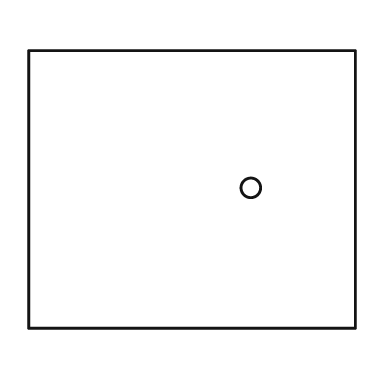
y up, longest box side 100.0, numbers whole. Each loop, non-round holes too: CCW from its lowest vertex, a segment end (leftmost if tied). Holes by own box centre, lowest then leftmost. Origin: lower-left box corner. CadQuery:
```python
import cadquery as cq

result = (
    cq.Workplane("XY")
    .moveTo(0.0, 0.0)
    .lineTo(100.0, 0.0)
    .lineTo(100.0, 85.0)
    .lineTo(0.0, 85.0)
    .close()
    .moveTo(68.0, 43.0)
    .circle(3.0)
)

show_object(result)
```